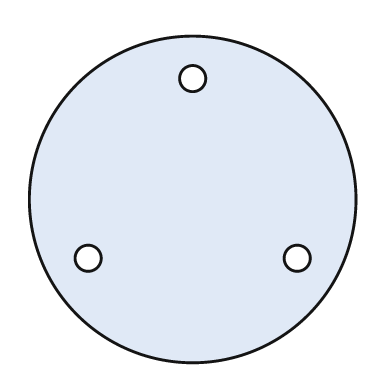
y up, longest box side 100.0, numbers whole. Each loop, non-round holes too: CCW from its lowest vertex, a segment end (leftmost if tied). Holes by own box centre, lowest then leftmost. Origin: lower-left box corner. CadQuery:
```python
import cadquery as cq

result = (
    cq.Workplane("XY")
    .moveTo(50.0, 50.0)
    .circle(50.0)
    .moveTo(18.0, 32.0)
    .circle(4.0)
    .moveTo(82.0, 32.0)
    .circle(4.0)
    .moveTo(50.0, 87.0)
    .circle(4.0)
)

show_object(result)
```